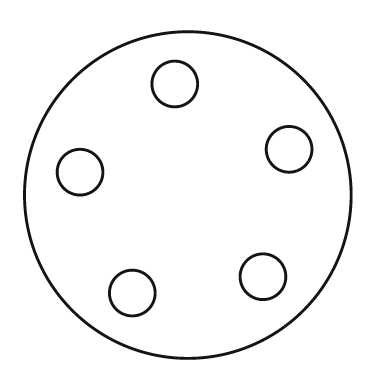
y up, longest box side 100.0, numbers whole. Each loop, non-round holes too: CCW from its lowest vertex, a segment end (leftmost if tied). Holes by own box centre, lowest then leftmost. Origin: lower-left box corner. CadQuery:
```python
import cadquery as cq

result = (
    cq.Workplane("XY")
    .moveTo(50.0, 50.0)
    .circle(50.0)
    .moveTo(33.0, 20.0)
    .circle(7.0)
    .moveTo(73.0, 25.0)
    .circle(7.0)
    .moveTo(17.0, 57.0)
    .circle(7.0)
    .moveTo(81.0, 64.0)
    .circle(7.0)
    .moveTo(46.0, 84.0)
    .circle(7.0)
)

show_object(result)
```